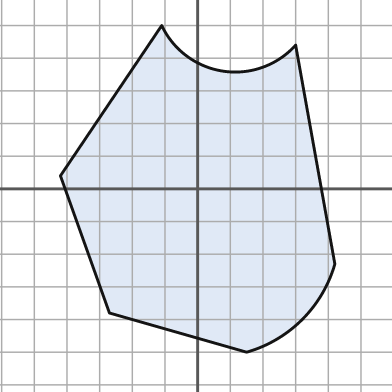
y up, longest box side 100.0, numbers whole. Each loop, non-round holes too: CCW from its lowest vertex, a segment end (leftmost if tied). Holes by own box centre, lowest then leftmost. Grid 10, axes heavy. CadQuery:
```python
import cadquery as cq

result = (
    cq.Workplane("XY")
    .moveTo(15.0, -50.0)
    .threePointArc((32.0, -40.0), (42.0, -23.0))
    .lineTo(30.0, 44.0)
    .threePointArc((8.0, 36.0), (-11.0, 50.0))
    .lineTo(-42.0, 4.0)
    .lineTo(-27.0, -38.0)
    .close()
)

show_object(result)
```